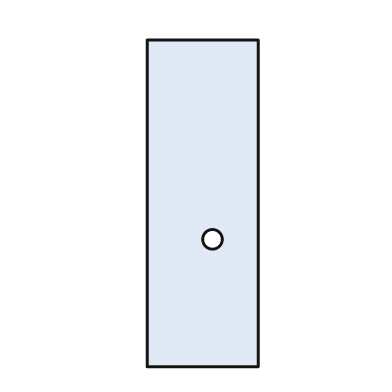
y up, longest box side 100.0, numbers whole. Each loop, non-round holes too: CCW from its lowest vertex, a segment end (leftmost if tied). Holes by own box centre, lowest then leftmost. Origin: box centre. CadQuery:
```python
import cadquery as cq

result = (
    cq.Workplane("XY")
    .moveTo(-17.0, -50.0)
    .lineTo(17.0, -50.0)
    .lineTo(17.0, 50.0)
    .lineTo(-17.0, 50.0)
    .close()
    .moveTo(3.0, -11.0)
    .circle(3.0)
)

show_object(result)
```